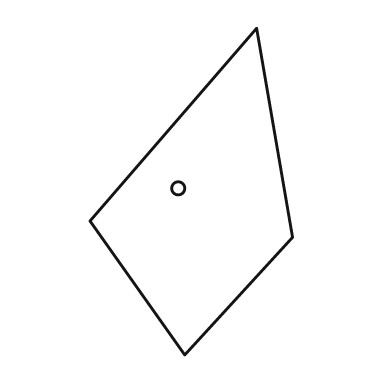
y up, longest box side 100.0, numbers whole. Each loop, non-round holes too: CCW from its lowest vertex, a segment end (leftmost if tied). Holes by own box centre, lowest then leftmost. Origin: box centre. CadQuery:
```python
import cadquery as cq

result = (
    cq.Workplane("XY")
    .moveTo(-2.0, -50.0)
    .lineTo(31.0, -14.0)
    .lineTo(20.0, 50.0)
    .lineTo(-31.0, -9.0)
    .close()
    .moveTo(-4.0, 1.0)
    .circle(2.0)
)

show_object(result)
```